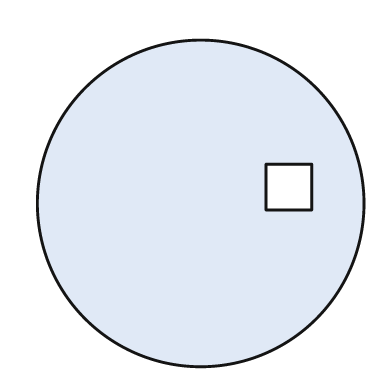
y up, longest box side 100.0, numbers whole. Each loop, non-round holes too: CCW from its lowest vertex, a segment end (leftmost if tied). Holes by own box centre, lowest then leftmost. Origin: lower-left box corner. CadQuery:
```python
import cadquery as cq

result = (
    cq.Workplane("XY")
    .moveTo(50.0, 50.0)
    .circle(50.0)
    .moveTo(70.0, 48.0)
    .lineTo(84.0, 48.0)
    .lineTo(84.0, 62.0)
    .lineTo(70.0, 62.0)
    .close()
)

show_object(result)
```